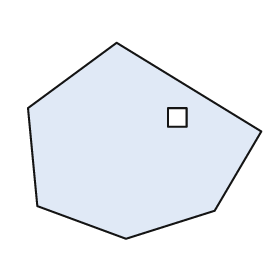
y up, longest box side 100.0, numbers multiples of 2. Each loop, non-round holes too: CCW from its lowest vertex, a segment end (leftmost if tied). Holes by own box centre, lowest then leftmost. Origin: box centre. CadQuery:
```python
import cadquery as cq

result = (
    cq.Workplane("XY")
    .moveTo(-8.0, -42.0)
    .lineTo(30.0, -30.0)
    .lineTo(50.0, 4.0)
    .lineTo(-12.0, 42.0)
    .lineTo(-50.0, 14.0)
    .lineTo(-46.0, -28.0)
    .close()
    .moveTo(10.0, 6.0)
    .lineTo(18.0, 6.0)
    .lineTo(18.0, 14.0)
    .lineTo(10.0, 14.0)
    .close()
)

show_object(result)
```